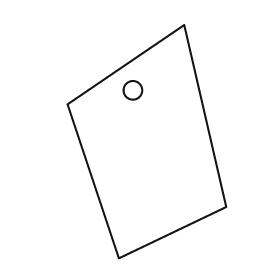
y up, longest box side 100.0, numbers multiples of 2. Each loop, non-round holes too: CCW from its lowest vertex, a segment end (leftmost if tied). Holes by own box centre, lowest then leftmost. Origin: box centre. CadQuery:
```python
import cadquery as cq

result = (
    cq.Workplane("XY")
    .moveTo(-12.0, -50.0)
    .lineTo(34.0, -28.0)
    .lineTo(16.0, 50.0)
    .lineTo(-34.0, 16.0)
    .close()
    .moveTo(-6.0, 22.0)
    .circle(4.0)
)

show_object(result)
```